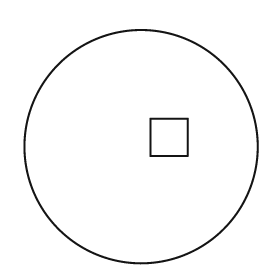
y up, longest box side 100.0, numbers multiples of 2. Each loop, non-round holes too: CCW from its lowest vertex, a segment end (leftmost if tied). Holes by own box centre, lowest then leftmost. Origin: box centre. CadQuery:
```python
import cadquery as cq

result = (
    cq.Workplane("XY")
    .moveTo(0.0, 0.0)
    .circle(50.0)
    .moveTo(4.0, -4.0)
    .lineTo(20.0, -4.0)
    .lineTo(20.0, 12.0)
    .lineTo(4.0, 12.0)
    .close()
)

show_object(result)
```